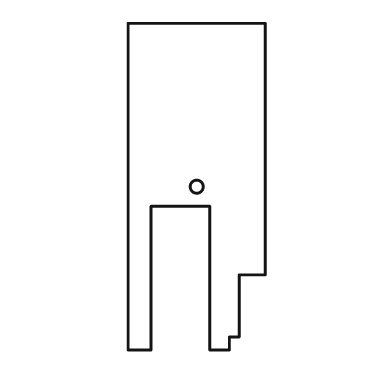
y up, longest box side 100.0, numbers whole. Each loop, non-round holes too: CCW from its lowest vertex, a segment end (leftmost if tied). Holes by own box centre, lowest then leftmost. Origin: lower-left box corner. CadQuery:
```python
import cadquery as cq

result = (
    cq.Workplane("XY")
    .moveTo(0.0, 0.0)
    .lineTo(7.0, 0.0)
    .lineTo(7.0, 44.0)
    .lineTo(25.0, 44.0)
    .lineTo(25.0, 0.0)
    .lineTo(31.0, 0.0)
    .lineTo(31.0, 4.0)
    .lineTo(34.0, 4.0)
    .lineTo(34.0, 23.0)
    .lineTo(42.0, 23.0)
    .lineTo(42.0, 100.0)
    .lineTo(0.0, 100.0)
    .close()
    .moveTo(21.0, 50.0)
    .circle(2.0)
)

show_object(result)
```